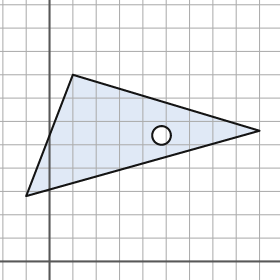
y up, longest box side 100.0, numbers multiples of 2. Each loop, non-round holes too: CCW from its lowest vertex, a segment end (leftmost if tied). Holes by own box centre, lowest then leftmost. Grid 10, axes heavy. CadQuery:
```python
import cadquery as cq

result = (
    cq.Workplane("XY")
    .moveTo(-10.0, 28.0)
    .lineTo(90.0, 56.0)
    .lineTo(10.0, 80.0)
    .close()
    .moveTo(48.0, 54.0)
    .circle(4.0)
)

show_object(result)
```